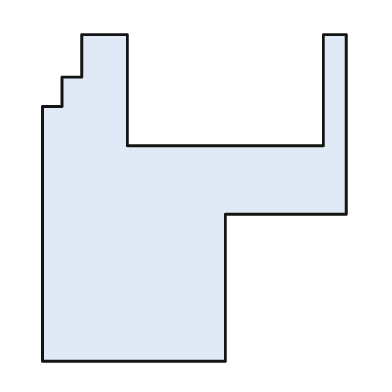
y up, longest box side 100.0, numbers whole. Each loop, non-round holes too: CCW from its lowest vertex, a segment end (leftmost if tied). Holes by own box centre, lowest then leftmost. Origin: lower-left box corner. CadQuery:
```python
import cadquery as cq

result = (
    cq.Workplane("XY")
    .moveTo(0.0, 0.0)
    .lineTo(56.0, 0.0)
    .lineTo(56.0, 45.0)
    .lineTo(93.0, 45.0)
    .lineTo(93.0, 100.0)
    .lineTo(86.0, 100.0)
    .lineTo(86.0, 66.0)
    .lineTo(26.0, 66.0)
    .lineTo(26.0, 100.0)
    .lineTo(12.0, 100.0)
    .lineTo(12.0, 87.0)
    .lineTo(6.0, 87.0)
    .lineTo(6.0, 78.0)
    .lineTo(0.0, 78.0)
    .close()
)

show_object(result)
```